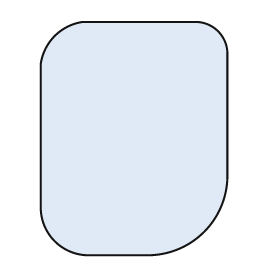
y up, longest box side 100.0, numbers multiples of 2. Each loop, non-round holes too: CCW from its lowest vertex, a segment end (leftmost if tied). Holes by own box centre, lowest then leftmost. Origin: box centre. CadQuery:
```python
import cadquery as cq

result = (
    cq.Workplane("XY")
    .moveTo(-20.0, -50.0)
    .lineTo(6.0, -50.0)
    .threePointArc((30.0, -40.0), (40.0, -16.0))
    .lineTo(40.0, 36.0)
    .threePointArc((36.0, 46.0), (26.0, 50.0))
    .lineTo(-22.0, 50.0)
    .threePointArc((-34.0, 44.0), (-40.0, 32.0))
    .lineTo(-40.0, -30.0)
    .threePointArc((-34.0, -44.0), (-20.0, -50.0))
    .close()
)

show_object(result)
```